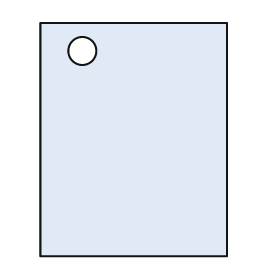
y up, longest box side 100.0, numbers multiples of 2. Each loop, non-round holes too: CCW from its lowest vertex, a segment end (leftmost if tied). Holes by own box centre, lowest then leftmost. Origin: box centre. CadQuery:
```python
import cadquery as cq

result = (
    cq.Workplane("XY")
    .moveTo(-40.0, -50.0)
    .lineTo(40.0, -50.0)
    .lineTo(40.0, 50.0)
    .lineTo(-40.0, 50.0)
    .close()
    .moveTo(-22.0, 38.0)
    .circle(6.0)
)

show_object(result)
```